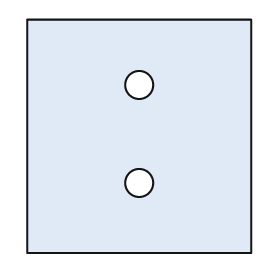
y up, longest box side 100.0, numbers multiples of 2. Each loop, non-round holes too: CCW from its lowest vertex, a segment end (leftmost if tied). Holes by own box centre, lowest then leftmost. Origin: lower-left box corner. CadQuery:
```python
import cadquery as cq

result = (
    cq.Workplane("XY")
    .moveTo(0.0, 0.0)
    .lineTo(96.0, 0.0)
    .lineTo(96.0, 100.0)
    .lineTo(0.0, 100.0)
    .close()
    .moveTo(48.0, 30.0)
    .circle(6.0)
    .moveTo(48.0, 72.0)
    .circle(6.0)
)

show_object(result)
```